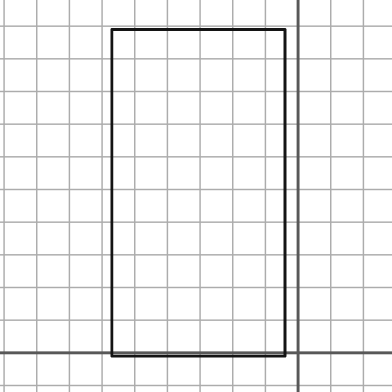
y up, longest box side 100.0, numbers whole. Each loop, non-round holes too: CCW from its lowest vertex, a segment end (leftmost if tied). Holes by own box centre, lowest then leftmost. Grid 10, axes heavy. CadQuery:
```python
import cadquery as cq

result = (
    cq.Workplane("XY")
    .moveTo(-57.0, -1.0)
    .lineTo(-4.0, -1.0)
    .lineTo(-4.0, 99.0)
    .lineTo(-57.0, 99.0)
    .close()
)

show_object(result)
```